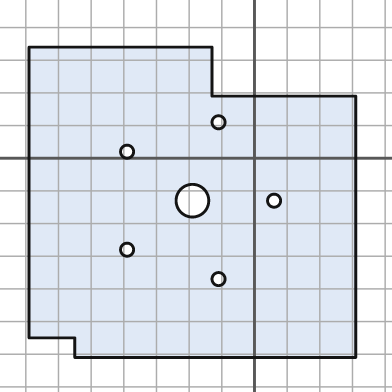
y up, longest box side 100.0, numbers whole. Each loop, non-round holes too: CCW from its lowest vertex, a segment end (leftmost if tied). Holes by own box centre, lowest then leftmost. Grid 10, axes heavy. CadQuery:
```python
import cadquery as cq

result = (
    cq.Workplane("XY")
    .moveTo(-55.0, -61.0)
    .lineTo(31.0, -61.0)
    .lineTo(31.0, 19.0)
    .lineTo(-13.0, 19.0)
    .lineTo(-13.0, 34.0)
    .lineTo(-69.0, 34.0)
    .lineTo(-69.0, -55.0)
    .lineTo(-55.0, -55.0)
    .close()
    .moveTo(-11.0, -37.0)
    .circle(2.0)
    .moveTo(-39.0, -28.0)
    .circle(2.0)
    .moveTo(-19.0, -13.0)
    .circle(5.0)
    .moveTo(6.0, -13.0)
    .circle(2.0)
    .moveTo(-39.0, 2.0)
    .circle(2.0)
    .moveTo(-11.0, 11.0)
    .circle(2.0)
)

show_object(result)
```